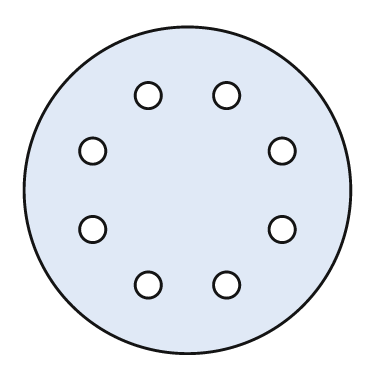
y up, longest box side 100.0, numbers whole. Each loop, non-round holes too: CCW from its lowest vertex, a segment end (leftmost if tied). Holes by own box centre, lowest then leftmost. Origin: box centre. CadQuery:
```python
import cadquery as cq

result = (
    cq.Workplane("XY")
    .moveTo(0.0, 0.0)
    .circle(50.0)
    .moveTo(-12.0, -29.0)
    .circle(4.0)
    .moveTo(12.0, -29.0)
    .circle(4.0)
    .moveTo(-29.0, -12.0)
    .circle(4.0)
    .moveTo(29.0, -12.0)
    .circle(4.0)
    .moveTo(-29.0, 12.0)
    .circle(4.0)
    .moveTo(29.0, 12.0)
    .circle(4.0)
    .moveTo(-12.0, 29.0)
    .circle(4.0)
    .moveTo(12.0, 29.0)
    .circle(4.0)
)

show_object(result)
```